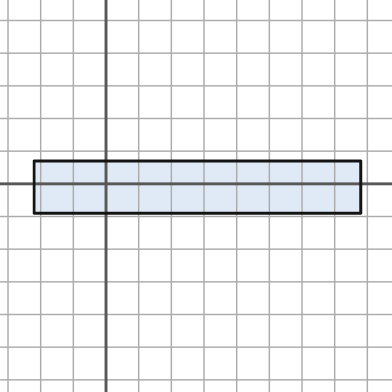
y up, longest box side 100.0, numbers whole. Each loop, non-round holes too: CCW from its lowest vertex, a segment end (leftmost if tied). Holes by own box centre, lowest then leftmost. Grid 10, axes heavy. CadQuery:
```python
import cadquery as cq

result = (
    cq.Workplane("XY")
    .moveTo(-22.0, -9.0)
    .lineTo(78.0, -9.0)
    .lineTo(78.0, 7.0)
    .lineTo(-22.0, 7.0)
    .close()
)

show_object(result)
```